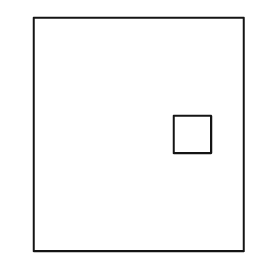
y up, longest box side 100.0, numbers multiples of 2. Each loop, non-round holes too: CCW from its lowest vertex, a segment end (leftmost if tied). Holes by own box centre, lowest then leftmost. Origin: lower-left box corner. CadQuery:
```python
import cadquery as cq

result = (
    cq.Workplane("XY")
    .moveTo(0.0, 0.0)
    .lineTo(90.0, 0.0)
    .lineTo(90.0, 100.0)
    .lineTo(0.0, 100.0)
    .close()
    .moveTo(60.0, 42.0)
    .lineTo(76.0, 42.0)
    .lineTo(76.0, 58.0)
    .lineTo(60.0, 58.0)
    .close()
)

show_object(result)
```